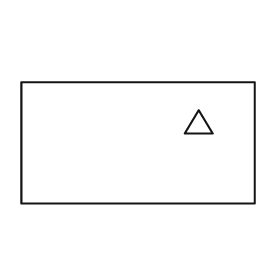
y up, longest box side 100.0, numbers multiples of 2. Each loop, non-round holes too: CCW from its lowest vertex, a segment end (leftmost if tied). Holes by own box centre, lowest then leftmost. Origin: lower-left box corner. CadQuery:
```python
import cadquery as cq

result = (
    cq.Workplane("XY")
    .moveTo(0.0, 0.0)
    .lineTo(100.0, 0.0)
    .lineTo(100.0, 52.0)
    .lineTo(0.0, 52.0)
    .close()
    .moveTo(70.0, 30.0)
    .lineTo(82.0, 30.0)
    .lineTo(76.0, 40.0)
    .close()
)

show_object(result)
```